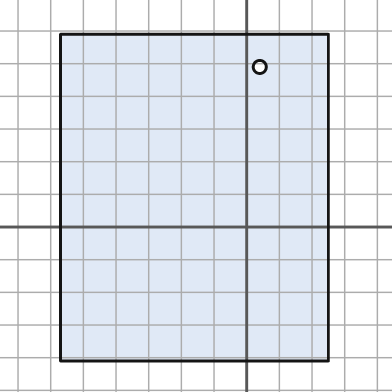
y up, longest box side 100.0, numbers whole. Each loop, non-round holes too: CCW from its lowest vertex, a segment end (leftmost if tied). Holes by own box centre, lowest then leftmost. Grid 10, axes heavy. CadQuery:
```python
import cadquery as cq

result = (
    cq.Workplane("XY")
    .moveTo(-57.0, -41.0)
    .lineTo(25.0, -41.0)
    .lineTo(25.0, 59.0)
    .lineTo(-57.0, 59.0)
    .close()
    .moveTo(4.0, 49.0)
    .circle(2.0)
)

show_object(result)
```